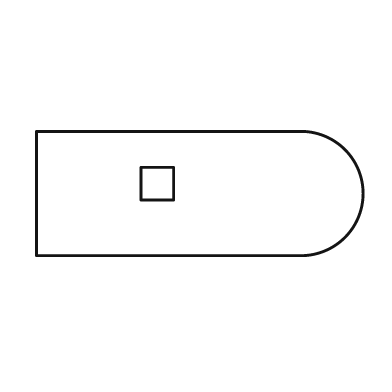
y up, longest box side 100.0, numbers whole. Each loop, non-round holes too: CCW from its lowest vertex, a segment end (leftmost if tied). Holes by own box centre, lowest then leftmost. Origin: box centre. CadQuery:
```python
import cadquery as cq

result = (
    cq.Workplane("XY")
    .moveTo(-50.0, -19.0)
    .lineTo(32.0, -19.0)
    .threePointArc((50.0, 0.0), (32.0, 19.0))
    .lineTo(-50.0, 19.0)
    .close()
    .moveTo(-18.0, -2.0)
    .lineTo(-8.0, -2.0)
    .lineTo(-8.0, 8.0)
    .lineTo(-18.0, 8.0)
    .close()
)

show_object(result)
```